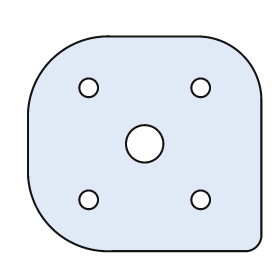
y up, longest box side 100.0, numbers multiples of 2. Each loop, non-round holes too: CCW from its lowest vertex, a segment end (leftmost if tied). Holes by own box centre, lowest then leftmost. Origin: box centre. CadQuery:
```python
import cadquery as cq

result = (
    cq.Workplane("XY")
    .moveTo(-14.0, -46.0)
    .lineTo(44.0, -46.0)
    .threePointArc((48.0, -44.0), (50.0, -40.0))
    .lineTo(50.0, 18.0)
    .threePointArc((42.0, 38.0), (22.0, 46.0))
    .lineTo(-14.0, 46.0)
    .threePointArc((-40.0, 36.0), (-50.0, 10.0))
    .lineTo(-50.0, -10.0)
    .threePointArc((-40.0, -36.0), (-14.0, -46.0))
    .close()
    .moveTo(-24.0, -24.0)
    .circle(4.0)
    .moveTo(24.0, -24.0)
    .circle(4.0)
    .moveTo(0.0, 0.0)
    .circle(8.0)
    .moveTo(-24.0, 24.0)
    .circle(4.0)
    .moveTo(24.0, 24.0)
    .circle(4.0)
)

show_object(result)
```